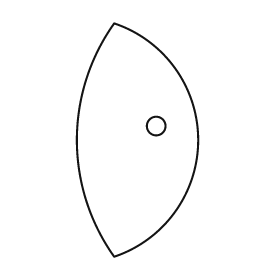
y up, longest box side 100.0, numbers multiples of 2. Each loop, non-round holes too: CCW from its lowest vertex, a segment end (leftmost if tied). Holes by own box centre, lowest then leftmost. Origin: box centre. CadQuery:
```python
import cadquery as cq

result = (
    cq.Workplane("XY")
    .moveTo(-10.0, -50.0)
    .threePointArc((26.0, 0.0), (-10.0, 50.0))
    .threePointArc((-26.0, 0.0), (-10.0, -50.0))
    .close()
    .moveTo(8.0, 6.0)
    .circle(4.0)
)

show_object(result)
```